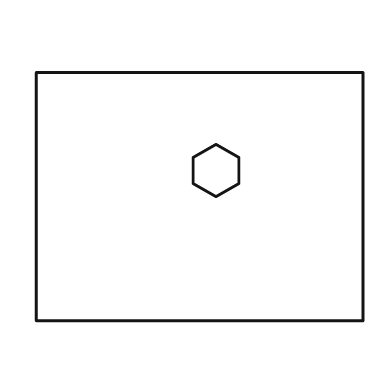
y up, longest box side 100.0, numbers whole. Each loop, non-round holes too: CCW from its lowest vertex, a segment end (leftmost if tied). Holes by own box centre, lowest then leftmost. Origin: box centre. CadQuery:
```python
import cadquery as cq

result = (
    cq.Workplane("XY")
    .moveTo(-50.0, -38.0)
    .lineTo(50.0, -38.0)
    .lineTo(50.0, 38.0)
    .lineTo(-50.0, 38.0)
    .close()
    .moveTo(5.0, 0.0)
    .lineTo(12.0, 4.0)
    .lineTo(12.0, 12.0)
    .lineTo(5.0, 16.0)
    .lineTo(-2.0, 12.0)
    .lineTo(-2.0, 4.0)
    .close()
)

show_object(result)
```